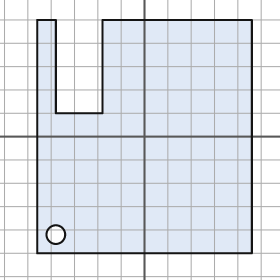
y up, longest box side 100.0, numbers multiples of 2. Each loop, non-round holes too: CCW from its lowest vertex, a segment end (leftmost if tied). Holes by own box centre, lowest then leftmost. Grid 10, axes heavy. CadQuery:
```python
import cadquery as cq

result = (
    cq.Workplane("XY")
    .moveTo(-46.0, -50.0)
    .lineTo(46.0, -50.0)
    .lineTo(46.0, 50.0)
    .lineTo(-18.0, 50.0)
    .lineTo(-18.0, 10.0)
    .lineTo(-38.0, 10.0)
    .lineTo(-38.0, 50.0)
    .lineTo(-46.0, 50.0)
    .close()
    .moveTo(-38.0, -42.0)
    .circle(4.0)
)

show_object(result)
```